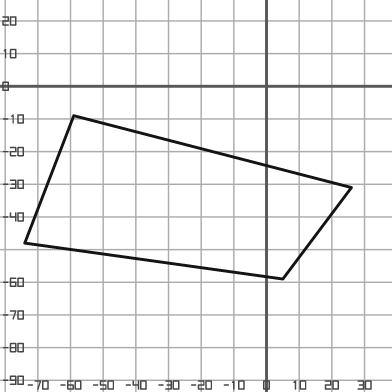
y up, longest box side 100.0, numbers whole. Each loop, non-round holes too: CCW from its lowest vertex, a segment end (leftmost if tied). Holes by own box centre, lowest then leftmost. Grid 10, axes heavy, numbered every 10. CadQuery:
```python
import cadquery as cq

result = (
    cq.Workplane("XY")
    .moveTo(5.0, -59.0)
    .lineTo(26.0, -31.0)
    .lineTo(-59.0, -9.0)
    .lineTo(-74.0, -48.0)
    .close()
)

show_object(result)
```